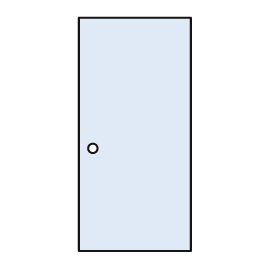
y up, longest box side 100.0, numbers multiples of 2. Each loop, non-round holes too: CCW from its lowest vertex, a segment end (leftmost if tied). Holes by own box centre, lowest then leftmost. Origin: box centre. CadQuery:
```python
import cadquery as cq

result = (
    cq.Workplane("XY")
    .moveTo(-24.0, -50.0)
    .lineTo(24.0, -50.0)
    .lineTo(24.0, 50.0)
    .lineTo(-24.0, 50.0)
    .close()
    .moveTo(-18.0, -6.0)
    .circle(2.0)
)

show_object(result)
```